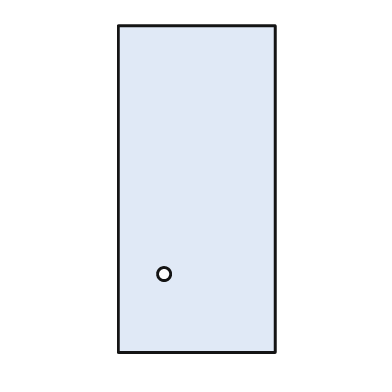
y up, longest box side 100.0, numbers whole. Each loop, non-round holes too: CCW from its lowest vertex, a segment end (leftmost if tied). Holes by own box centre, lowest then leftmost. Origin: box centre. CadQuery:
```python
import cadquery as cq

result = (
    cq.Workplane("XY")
    .moveTo(-24.0, -50.0)
    .lineTo(24.0, -50.0)
    .lineTo(24.0, 50.0)
    .lineTo(-24.0, 50.0)
    .close()
    .moveTo(-10.0, -26.0)
    .circle(2.0)
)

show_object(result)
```